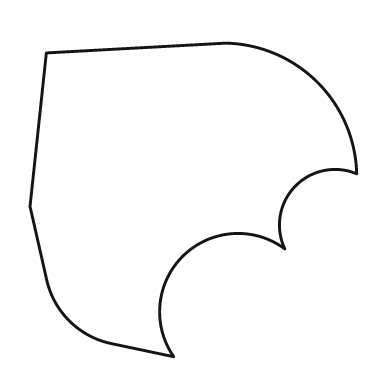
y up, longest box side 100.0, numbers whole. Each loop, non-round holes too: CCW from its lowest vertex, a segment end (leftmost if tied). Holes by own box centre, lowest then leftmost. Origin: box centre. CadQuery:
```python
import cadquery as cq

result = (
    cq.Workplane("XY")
    .moveTo(-6.0, -48.0)
    .threePointArc((-3.0, -17.0), (28.0, -15.0))
    .threePointArc((31.0, 4.0), (50.0, 8.0))
    .threePointArc((38.0, 36.0), (10.0, 48.0))
    .lineTo(-45.0, 45.0)
    .lineTo(-50.0, -2.0)
    .lineTo(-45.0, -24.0)
    .threePointArc((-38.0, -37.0), (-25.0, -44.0))
    .close()
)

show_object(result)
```